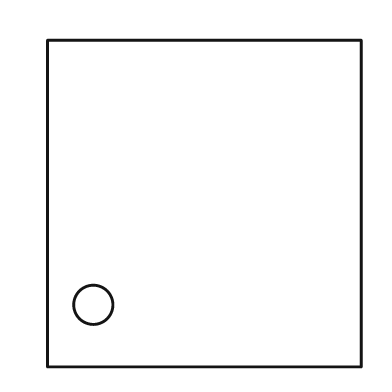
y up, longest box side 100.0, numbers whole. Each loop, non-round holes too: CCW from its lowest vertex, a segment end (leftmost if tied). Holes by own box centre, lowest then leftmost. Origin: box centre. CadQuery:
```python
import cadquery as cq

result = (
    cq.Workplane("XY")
    .moveTo(-48.0, -50.0)
    .lineTo(48.0, -50.0)
    .lineTo(48.0, 50.0)
    .lineTo(-48.0, 50.0)
    .close()
    .moveTo(-34.0, -31.0)
    .circle(6.0)
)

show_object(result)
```